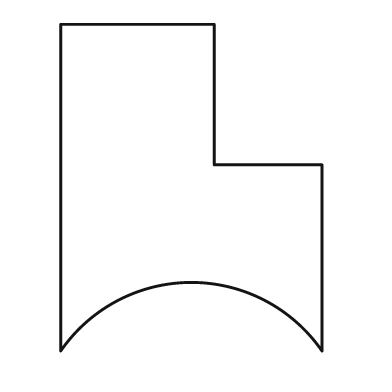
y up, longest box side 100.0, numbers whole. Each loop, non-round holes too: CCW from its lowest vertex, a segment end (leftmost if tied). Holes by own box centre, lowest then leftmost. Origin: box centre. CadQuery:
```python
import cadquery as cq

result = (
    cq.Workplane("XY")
    .moveTo(-40.0, -50.0)
    .threePointArc((0.0, -29.0), (40.0, -50.0))
    .lineTo(40.0, 7.0)
    .lineTo(7.0, 7.0)
    .lineTo(7.0, 50.0)
    .lineTo(-40.0, 50.0)
    .close()
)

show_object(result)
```